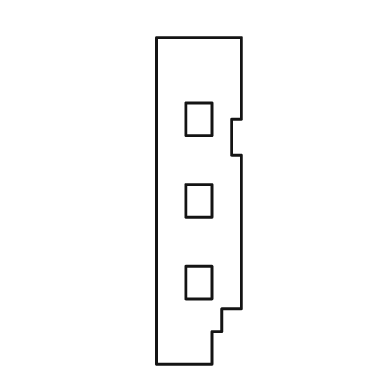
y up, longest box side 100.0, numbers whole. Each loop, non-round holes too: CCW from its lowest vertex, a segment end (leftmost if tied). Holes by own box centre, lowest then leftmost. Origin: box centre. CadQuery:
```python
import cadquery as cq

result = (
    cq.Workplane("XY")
    .moveTo(-13.0, -50.0)
    .lineTo(4.0, -50.0)
    .lineTo(4.0, -40.0)
    .lineTo(7.0, -40.0)
    .lineTo(7.0, -33.0)
    .lineTo(13.0, -33.0)
    .lineTo(13.0, 14.0)
    .lineTo(10.0, 14.0)
    .lineTo(10.0, 25.0)
    .lineTo(13.0, 25.0)
    .lineTo(13.0, 50.0)
    .lineTo(-13.0, 50.0)
    .close()
    .moveTo(-4.0, -30.0)
    .lineTo(4.0, -30.0)
    .lineTo(4.0, -20.0)
    .lineTo(-4.0, -20.0)
    .close()
    .moveTo(-4.0, -5.0)
    .lineTo(4.0, -5.0)
    .lineTo(4.0, 5.0)
    .lineTo(-4.0, 5.0)
    .close()
    .moveTo(-4.0, 20.0)
    .lineTo(4.0, 20.0)
    .lineTo(4.0, 30.0)
    .lineTo(-4.0, 30.0)
    .close()
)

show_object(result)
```